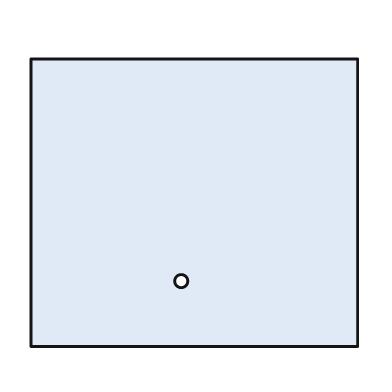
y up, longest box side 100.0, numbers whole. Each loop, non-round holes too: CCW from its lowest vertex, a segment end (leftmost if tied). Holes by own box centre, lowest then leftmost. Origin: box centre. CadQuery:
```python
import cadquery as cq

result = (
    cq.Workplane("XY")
    .moveTo(-50.0, -44.0)
    .lineTo(50.0, -44.0)
    .lineTo(50.0, 44.0)
    .lineTo(-50.0, 44.0)
    .close()
    .moveTo(-4.0, -24.0)
    .circle(2.0)
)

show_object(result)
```